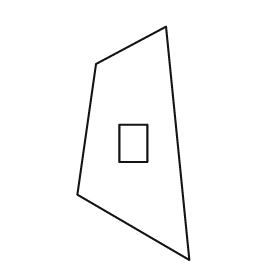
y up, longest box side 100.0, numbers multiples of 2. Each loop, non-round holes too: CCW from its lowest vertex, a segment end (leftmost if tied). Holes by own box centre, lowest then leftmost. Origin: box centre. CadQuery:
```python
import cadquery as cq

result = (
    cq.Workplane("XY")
    .moveTo(24.0, -50.0)
    .lineTo(14.0, 50.0)
    .lineTo(-16.0, 34.0)
    .lineTo(-24.0, -22.0)
    .close()
    .moveTo(-6.0, -8.0)
    .lineTo(6.0, -8.0)
    .lineTo(6.0, 8.0)
    .lineTo(-6.0, 8.0)
    .close()
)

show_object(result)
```